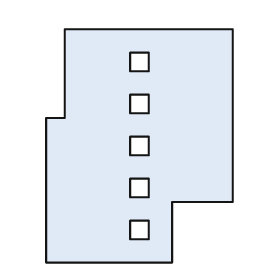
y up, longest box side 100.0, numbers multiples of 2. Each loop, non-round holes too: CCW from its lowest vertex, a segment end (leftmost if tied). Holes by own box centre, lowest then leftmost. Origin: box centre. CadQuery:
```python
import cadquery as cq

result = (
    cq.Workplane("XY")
    .moveTo(-40.0, -50.0)
    .lineTo(14.0, -50.0)
    .lineTo(14.0, -24.0)
    .lineTo(40.0, -24.0)
    .lineTo(40.0, 50.0)
    .lineTo(-32.0, 50.0)
    .lineTo(-32.0, 12.0)
    .lineTo(-40.0, 12.0)
    .close()
    .moveTo(-4.0, -40.0)
    .lineTo(4.0, -40.0)
    .lineTo(4.0, -32.0)
    .lineTo(-4.0, -32.0)
    .close()
    .moveTo(-4.0, -22.0)
    .lineTo(4.0, -22.0)
    .lineTo(4.0, -14.0)
    .lineTo(-4.0, -14.0)
    .close()
    .moveTo(-4.0, -4.0)
    .lineTo(4.0, -4.0)
    .lineTo(4.0, 4.0)
    .lineTo(-4.0, 4.0)
    .close()
    .moveTo(-4.0, 14.0)
    .lineTo(4.0, 14.0)
    .lineTo(4.0, 22.0)
    .lineTo(-4.0, 22.0)
    .close()
    .moveTo(-4.0, 32.0)
    .lineTo(4.0, 32.0)
    .lineTo(4.0, 40.0)
    .lineTo(-4.0, 40.0)
    .close()
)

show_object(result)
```